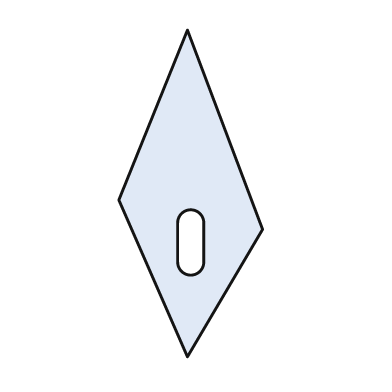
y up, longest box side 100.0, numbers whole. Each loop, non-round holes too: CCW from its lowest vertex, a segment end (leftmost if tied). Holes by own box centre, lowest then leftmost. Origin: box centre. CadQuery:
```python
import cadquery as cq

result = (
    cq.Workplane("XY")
    .moveTo(-1.0, -50.0)
    .lineTo(22.0, -11.0)
    .lineTo(-1.0, 50.0)
    .lineTo(-22.0, -2.0)
    .close()
    .moveTo(-4.0, -21.0)
    .threePointArc((0.0, -25.0), (4.0, -21.0))
    .lineTo(4.0, -9.0)
    .threePointArc((0.0, -5.0), (-4.0, -9.0))
    .close()
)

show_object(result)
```